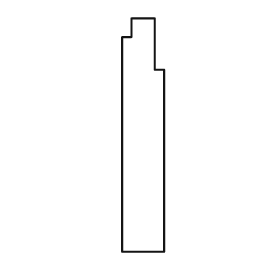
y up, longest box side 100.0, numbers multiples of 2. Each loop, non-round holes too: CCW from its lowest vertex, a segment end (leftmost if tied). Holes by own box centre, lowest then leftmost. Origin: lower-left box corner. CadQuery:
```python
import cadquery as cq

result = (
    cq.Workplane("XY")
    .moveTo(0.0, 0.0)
    .lineTo(18.0, 0.0)
    .lineTo(18.0, 78.0)
    .lineTo(14.0, 78.0)
    .lineTo(14.0, 100.0)
    .lineTo(4.0, 100.0)
    .lineTo(4.0, 92.0)
    .lineTo(0.0, 92.0)
    .close()
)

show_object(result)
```